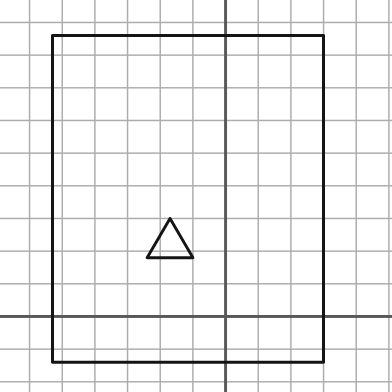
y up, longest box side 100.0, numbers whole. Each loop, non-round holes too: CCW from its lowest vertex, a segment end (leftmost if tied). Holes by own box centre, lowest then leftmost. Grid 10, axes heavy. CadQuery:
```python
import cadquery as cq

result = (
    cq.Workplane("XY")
    .moveTo(-53.0, -14.0)
    .lineTo(30.0, -14.0)
    .lineTo(30.0, 86.0)
    .lineTo(-53.0, 86.0)
    .close()
    .moveTo(-24.0, 18.0)
    .lineTo(-10.0, 18.0)
    .lineTo(-17.0, 30.0)
    .close()
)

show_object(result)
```